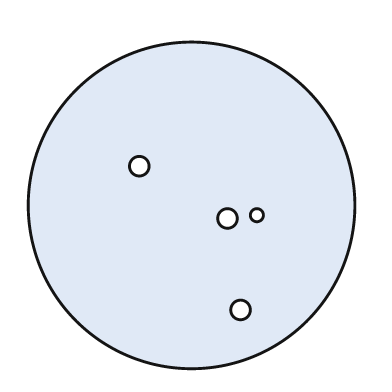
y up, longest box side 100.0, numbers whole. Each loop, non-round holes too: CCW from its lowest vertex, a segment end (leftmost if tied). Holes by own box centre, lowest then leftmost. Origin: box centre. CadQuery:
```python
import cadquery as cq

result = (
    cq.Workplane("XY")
    .moveTo(0.0, 0.0)
    .circle(50.0)
    .moveTo(15.0, -32.0)
    .circle(3.0)
    .moveTo(11.0, -4.0)
    .circle(3.0)
    .moveTo(20.0, -3.0)
    .circle(2.0)
    .moveTo(-16.0, 12.0)
    .circle(3.0)
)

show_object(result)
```